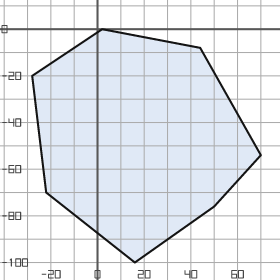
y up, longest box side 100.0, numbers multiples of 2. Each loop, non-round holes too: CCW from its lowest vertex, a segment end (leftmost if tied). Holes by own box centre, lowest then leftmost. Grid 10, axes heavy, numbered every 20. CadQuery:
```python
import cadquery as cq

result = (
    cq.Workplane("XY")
    .moveTo(16.0, -100.0)
    .lineTo(50.0, -76.0)
    .lineTo(70.0, -54.0)
    .lineTo(44.0, -8.0)
    .lineTo(2.0, 0.0)
    .lineTo(-28.0, -20.0)
    .lineTo(-22.0, -70.0)
    .close()
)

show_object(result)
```